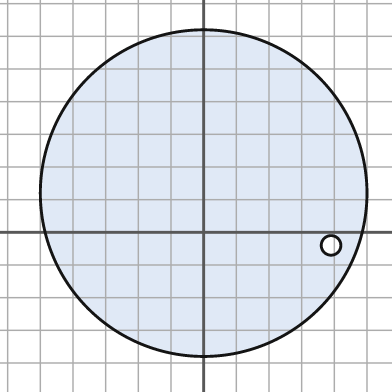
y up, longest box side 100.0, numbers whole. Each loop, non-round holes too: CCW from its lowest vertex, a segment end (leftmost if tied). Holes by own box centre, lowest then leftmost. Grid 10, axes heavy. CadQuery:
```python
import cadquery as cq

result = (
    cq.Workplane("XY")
    .moveTo(0.0, 12.0)
    .circle(50.0)
    .moveTo(39.0, -4.0)
    .circle(3.0)
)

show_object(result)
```